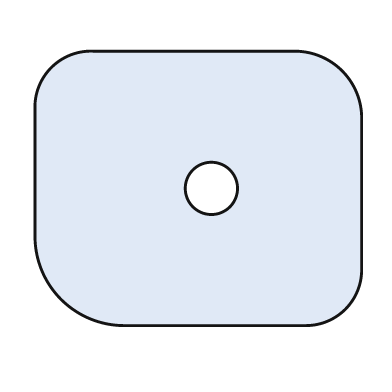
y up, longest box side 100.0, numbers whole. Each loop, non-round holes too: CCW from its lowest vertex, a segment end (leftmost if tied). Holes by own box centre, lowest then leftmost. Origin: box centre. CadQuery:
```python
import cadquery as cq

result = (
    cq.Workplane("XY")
    .moveTo(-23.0, -42.0)
    .lineTo(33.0, -42.0)
    .threePointArc((45.0, -37.0), (50.0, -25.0))
    .lineTo(50.0, 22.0)
    .threePointArc((44.0, 36.0), (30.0, 42.0))
    .lineTo(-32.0, 42.0)
    .threePointArc((-45.0, 37.0), (-50.0, 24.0))
    .lineTo(-50.0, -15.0)
    .threePointArc((-42.0, -34.0), (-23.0, -42.0))
    .close()
    .moveTo(4.0, 0.0)
    .circle(8.0)
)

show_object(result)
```